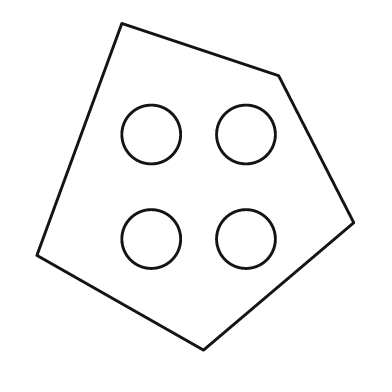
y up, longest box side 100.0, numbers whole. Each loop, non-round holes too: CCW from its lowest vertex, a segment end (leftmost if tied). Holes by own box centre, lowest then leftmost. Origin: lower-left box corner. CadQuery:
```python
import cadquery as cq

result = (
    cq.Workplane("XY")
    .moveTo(51.0, 0.0)
    .lineTo(97.0, 39.0)
    .lineTo(74.0, 84.0)
    .lineTo(26.0, 100.0)
    .lineTo(0.0, 29.0)
    .close()
    .moveTo(35.0, 34.0)
    .circle(9.0)
    .moveTo(64.0, 34.0)
    .circle(9.0)
    .moveTo(35.0, 66.0)
    .circle(9.0)
    .moveTo(64.0, 66.0)
    .circle(9.0)
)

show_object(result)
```